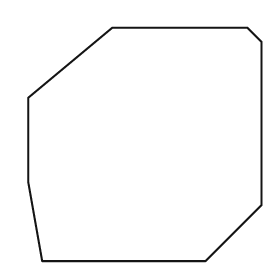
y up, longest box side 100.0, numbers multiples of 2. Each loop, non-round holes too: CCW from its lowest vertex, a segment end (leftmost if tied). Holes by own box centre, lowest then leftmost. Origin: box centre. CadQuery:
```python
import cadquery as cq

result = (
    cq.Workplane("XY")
    .moveTo(-44.0, -50.0)
    .lineTo(26.0, -50.0)
    .lineTo(50.0, -26.0)
    .lineTo(50.0, 44.0)
    .lineTo(44.0, 50.0)
    .lineTo(-14.0, 50.0)
    .lineTo(-50.0, 20.0)
    .lineTo(-50.0, -16.0)
    .close()
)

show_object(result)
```